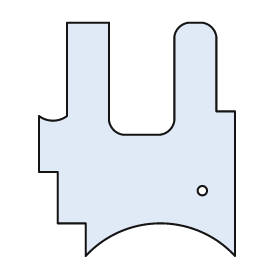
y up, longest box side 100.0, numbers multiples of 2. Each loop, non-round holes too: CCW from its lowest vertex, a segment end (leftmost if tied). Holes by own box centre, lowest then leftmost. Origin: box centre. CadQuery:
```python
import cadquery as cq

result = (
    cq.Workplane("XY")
    .moveTo(-22.0, -50.0)
    .threePointArc((10.0, -36.0), (42.0, -50.0))
    .lineTo(42.0, 12.0)
    .lineTo(34.0, 12.0)
    .lineTo(34.0, 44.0)
    .threePointArc((32.0, 48.0), (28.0, 50.0))
    .lineTo(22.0, 50.0)
    .threePointArc((18.0, 48.0), (16.0, 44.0))
    .lineTo(16.0, 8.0)
    .threePointArc((14.0, 4.0), (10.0, 2.0))
    .lineTo(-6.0, 2.0)
    .threePointArc((-10.0, 4.0), (-12.0, 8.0))
    .lineTo(-12.0, 50.0)
    .lineTo(-30.0, 50.0)
    .lineTo(-30.0, 10.0)
    .threePointArc((-36.0, 8.0), (-42.0, 10.0))
    .lineTo(-42.0, -14.0)
    .lineTo(-34.0, -14.0)
    .lineTo(-34.0, -36.0)
    .lineTo(-22.0, -36.0)
    .close()
    .moveTo(28.0, -22.0)
    .circle(2.0)
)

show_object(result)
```